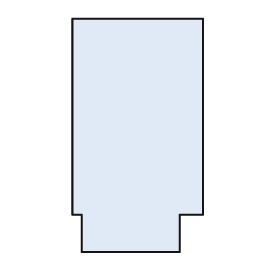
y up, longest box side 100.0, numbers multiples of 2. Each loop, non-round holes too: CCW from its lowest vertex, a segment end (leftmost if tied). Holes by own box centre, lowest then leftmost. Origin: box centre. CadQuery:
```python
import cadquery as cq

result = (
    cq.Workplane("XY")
    .moveTo(-24.0, -50.0)
    .lineTo(18.0, -50.0)
    .lineTo(18.0, -34.0)
    .lineTo(28.0, -34.0)
    .lineTo(28.0, 50.0)
    .lineTo(-28.0, 50.0)
    .lineTo(-28.0, -34.0)
    .lineTo(-24.0, -34.0)
    .close()
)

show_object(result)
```